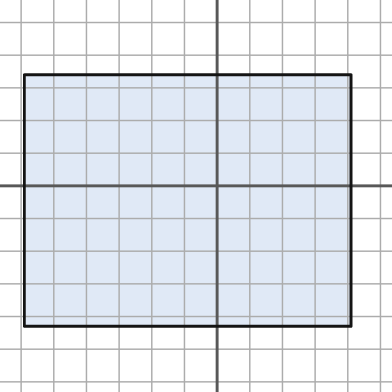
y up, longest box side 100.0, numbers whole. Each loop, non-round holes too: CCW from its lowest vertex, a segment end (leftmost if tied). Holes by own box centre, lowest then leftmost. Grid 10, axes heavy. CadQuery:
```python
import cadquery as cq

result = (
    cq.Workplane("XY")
    .moveTo(-59.0, -43.0)
    .lineTo(41.0, -43.0)
    .lineTo(41.0, 34.0)
    .lineTo(-59.0, 34.0)
    .close()
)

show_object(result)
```